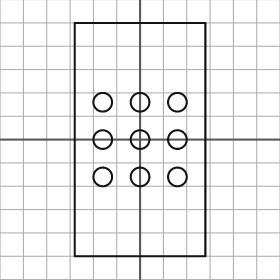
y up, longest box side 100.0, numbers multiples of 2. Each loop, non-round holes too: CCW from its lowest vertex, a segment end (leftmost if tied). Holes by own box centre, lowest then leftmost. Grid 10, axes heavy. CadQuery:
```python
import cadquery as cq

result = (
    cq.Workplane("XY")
    .moveTo(-28.0, -50.0)
    .lineTo(28.0, -50.0)
    .lineTo(28.0, 50.0)
    .lineTo(-28.0, 50.0)
    .close()
    .moveTo(-16.0, -16.0)
    .circle(4.0)
    .moveTo(0.0, -16.0)
    .circle(4.0)
    .moveTo(16.0, -16.0)
    .circle(4.0)
    .moveTo(-16.0, 0.0)
    .circle(4.0)
    .moveTo(0.0, 0.0)
    .circle(4.0)
    .moveTo(16.0, 0.0)
    .circle(4.0)
    .moveTo(-16.0, 16.0)
    .circle(4.0)
    .moveTo(0.0, 16.0)
    .circle(4.0)
    .moveTo(16.0, 16.0)
    .circle(4.0)
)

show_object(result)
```